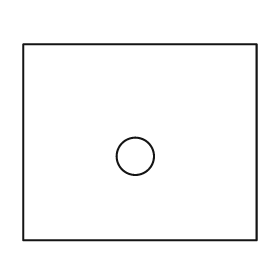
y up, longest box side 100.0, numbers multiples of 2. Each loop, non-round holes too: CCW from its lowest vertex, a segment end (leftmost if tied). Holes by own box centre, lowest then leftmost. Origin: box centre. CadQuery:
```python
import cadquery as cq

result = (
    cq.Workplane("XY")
    .moveTo(-50.0, -42.0)
    .lineTo(50.0, -42.0)
    .lineTo(50.0, 42.0)
    .lineTo(-50.0, 42.0)
    .close()
    .moveTo(-2.0, -6.0)
    .circle(8.0)
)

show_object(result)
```